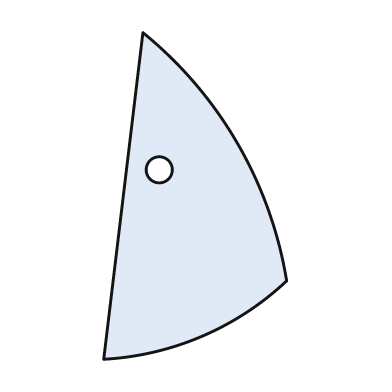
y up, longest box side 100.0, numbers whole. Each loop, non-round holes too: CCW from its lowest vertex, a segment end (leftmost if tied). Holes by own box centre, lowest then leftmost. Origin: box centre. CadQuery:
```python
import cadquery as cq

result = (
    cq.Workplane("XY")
    .moveTo(-28.0, -50.0)
    .threePointArc((2.0, -43.0), (28.0, -26.0))
    .threePointArc((13.0, 16.0), (-16.0, 50.0))
    .close()
    .moveTo(-11.0, 8.0)
    .circle(4.0)
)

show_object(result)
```